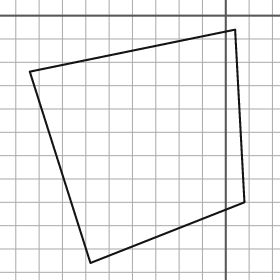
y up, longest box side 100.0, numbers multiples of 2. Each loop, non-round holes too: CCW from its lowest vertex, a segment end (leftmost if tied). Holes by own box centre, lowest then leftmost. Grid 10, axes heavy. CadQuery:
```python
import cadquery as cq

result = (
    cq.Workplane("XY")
    .moveTo(-58.0, -106.0)
    .lineTo(8.0, -80.0)
    .lineTo(4.0, -6.0)
    .lineTo(-84.0, -24.0)
    .close()
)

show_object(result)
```